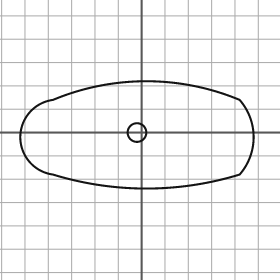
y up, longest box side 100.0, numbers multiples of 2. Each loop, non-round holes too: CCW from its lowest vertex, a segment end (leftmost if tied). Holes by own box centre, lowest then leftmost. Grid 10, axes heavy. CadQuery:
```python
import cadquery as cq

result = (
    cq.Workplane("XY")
    .moveTo(-38.0, -18.0)
    .threePointArc((2.0, -24.0), (42.0, -18.0))
    .threePointArc((48.0, -2.0), (42.0, 14.0))
    .threePointArc((2.0, 22.0), (-38.0, 14.0))
    .threePointArc((-52.0, -2.0), (-38.0, -18.0))
    .close()
    .moveTo(-2.0, 0.0)
    .circle(4.0)
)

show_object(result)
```